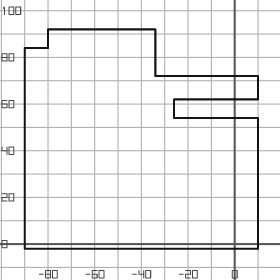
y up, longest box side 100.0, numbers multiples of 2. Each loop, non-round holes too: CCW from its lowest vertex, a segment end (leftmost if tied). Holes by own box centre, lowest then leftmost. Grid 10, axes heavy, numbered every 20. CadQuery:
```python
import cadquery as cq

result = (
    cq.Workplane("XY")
    .moveTo(-90.0, -2.0)
    .lineTo(10.0, -2.0)
    .lineTo(10.0, 54.0)
    .lineTo(-26.0, 54.0)
    .lineTo(-26.0, 62.0)
    .lineTo(10.0, 62.0)
    .lineTo(10.0, 72.0)
    .lineTo(-34.0, 72.0)
    .lineTo(-34.0, 92.0)
    .lineTo(-80.0, 92.0)
    .lineTo(-80.0, 84.0)
    .lineTo(-90.0, 84.0)
    .close()
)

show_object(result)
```